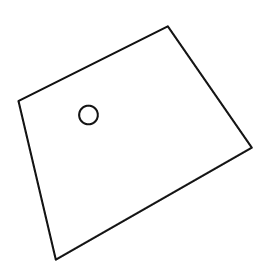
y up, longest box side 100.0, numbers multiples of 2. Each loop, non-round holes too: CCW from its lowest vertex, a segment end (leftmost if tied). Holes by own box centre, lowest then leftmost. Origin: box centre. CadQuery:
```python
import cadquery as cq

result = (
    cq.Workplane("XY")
    .moveTo(-34.0, -50.0)
    .lineTo(50.0, -2.0)
    .lineTo(14.0, 50.0)
    .lineTo(-50.0, 18.0)
    .close()
    .moveTo(-20.0, 12.0)
    .circle(4.0)
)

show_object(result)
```